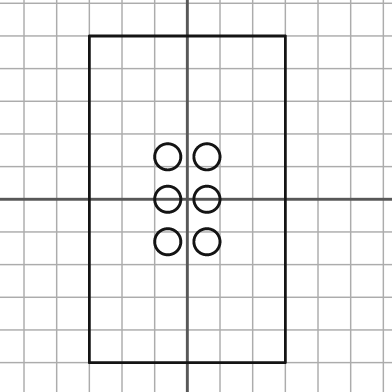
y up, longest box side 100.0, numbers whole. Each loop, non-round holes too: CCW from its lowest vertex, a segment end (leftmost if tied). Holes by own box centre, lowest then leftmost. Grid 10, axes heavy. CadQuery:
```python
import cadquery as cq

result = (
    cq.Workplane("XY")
    .moveTo(-30.0, -50.0)
    .lineTo(30.0, -50.0)
    .lineTo(30.0, 50.0)
    .lineTo(-30.0, 50.0)
    .close()
    .moveTo(-6.0, -13.0)
    .circle(4.0)
    .moveTo(6.0, -13.0)
    .circle(4.0)
    .moveTo(-6.0, 0.0)
    .circle(4.0)
    .moveTo(6.0, 0.0)
    .circle(4.0)
    .moveTo(-6.0, 13.0)
    .circle(4.0)
    .moveTo(6.0, 13.0)
    .circle(4.0)
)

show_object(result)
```